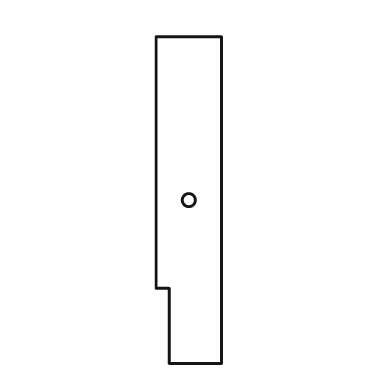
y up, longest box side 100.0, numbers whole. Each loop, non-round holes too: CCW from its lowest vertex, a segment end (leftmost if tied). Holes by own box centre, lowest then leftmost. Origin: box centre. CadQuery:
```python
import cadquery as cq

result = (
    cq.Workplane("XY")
    .moveTo(-6.0, -50.0)
    .lineTo(10.0, -50.0)
    .lineTo(10.0, 50.0)
    .lineTo(-10.0, 50.0)
    .lineTo(-10.0, -27.0)
    .lineTo(-6.0, -27.0)
    .close()
    .moveTo(0.0, 0.0)
    .circle(2.0)
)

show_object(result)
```